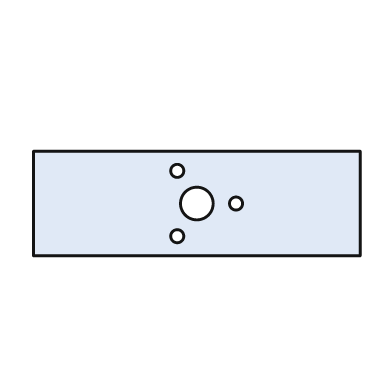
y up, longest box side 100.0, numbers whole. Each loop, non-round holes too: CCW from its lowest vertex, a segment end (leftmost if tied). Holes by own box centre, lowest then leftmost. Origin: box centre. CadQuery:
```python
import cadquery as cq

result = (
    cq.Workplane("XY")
    .moveTo(-50.0, -16.0)
    .lineTo(50.0, -16.0)
    .lineTo(50.0, 16.0)
    .lineTo(-50.0, 16.0)
    .close()
    .moveTo(-6.0, -10.0)
    .circle(2.0)
    .moveTo(0.0, 0.0)
    .circle(5.0)
    .moveTo(12.0, 0.0)
    .circle(2.0)
    .moveTo(-6.0, 10.0)
    .circle(2.0)
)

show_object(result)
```